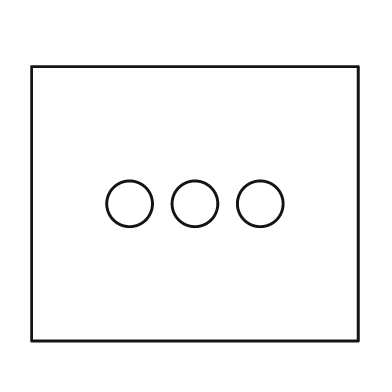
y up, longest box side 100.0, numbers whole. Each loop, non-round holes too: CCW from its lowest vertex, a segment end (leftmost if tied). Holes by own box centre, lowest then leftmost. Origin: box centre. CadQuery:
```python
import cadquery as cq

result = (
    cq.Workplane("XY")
    .moveTo(-50.0, -42.0)
    .lineTo(50.0, -42.0)
    .lineTo(50.0, 42.0)
    .lineTo(-50.0, 42.0)
    .close()
    .moveTo(-20.0, 0.0)
    .circle(7.0)
    .moveTo(0.0, 0.0)
    .circle(7.0)
    .moveTo(20.0, 0.0)
    .circle(7.0)
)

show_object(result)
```